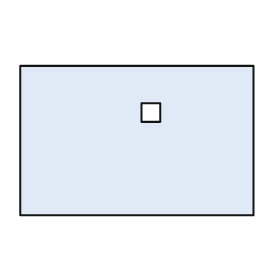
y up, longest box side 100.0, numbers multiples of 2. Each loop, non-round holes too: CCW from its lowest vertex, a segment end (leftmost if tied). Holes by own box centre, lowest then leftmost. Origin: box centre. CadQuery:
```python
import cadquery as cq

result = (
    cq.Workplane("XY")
    .moveTo(-50.0, -32.0)
    .lineTo(50.0, -32.0)
    .lineTo(50.0, 32.0)
    .lineTo(-50.0, 32.0)
    .close()
    .moveTo(2.0, 8.0)
    .lineTo(10.0, 8.0)
    .lineTo(10.0, 16.0)
    .lineTo(2.0, 16.0)
    .close()
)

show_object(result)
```